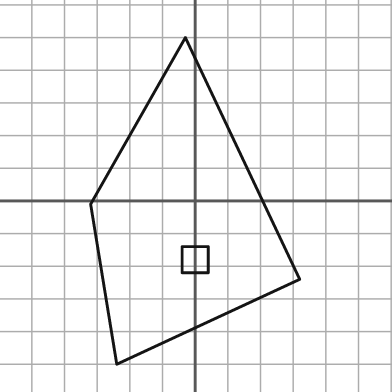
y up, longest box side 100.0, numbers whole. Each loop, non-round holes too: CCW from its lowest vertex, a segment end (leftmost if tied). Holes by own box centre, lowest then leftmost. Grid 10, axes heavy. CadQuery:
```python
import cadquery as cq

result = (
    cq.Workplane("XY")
    .moveTo(-24.0, -50.0)
    .lineTo(32.0, -24.0)
    .lineTo(-3.0, 50.0)
    .lineTo(-32.0, -1.0)
    .close()
    .moveTo(-4.0, -22.0)
    .lineTo(4.0, -22.0)
    .lineTo(4.0, -14.0)
    .lineTo(-4.0, -14.0)
    .close()
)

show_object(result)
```